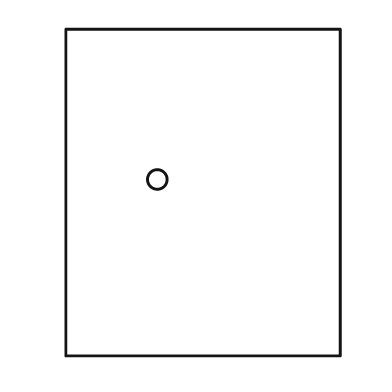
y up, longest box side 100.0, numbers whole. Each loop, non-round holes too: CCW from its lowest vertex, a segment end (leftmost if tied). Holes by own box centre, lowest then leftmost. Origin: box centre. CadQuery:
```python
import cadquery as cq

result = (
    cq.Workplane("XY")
    .moveTo(-42.0, -50.0)
    .lineTo(42.0, -50.0)
    .lineTo(42.0, 50.0)
    .lineTo(-42.0, 50.0)
    .close()
    .moveTo(-14.0, 4.0)
    .circle(3.0)
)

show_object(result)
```